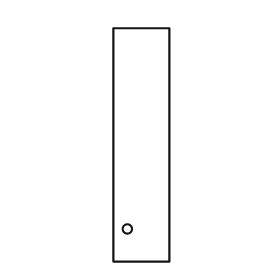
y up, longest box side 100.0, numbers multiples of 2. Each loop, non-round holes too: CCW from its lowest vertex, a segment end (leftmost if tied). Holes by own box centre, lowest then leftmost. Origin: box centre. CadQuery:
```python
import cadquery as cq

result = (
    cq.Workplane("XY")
    .moveTo(-12.0, -50.0)
    .lineTo(12.0, -50.0)
    .lineTo(12.0, 50.0)
    .lineTo(-12.0, 50.0)
    .close()
    .moveTo(-6.0, -36.0)
    .circle(2.0)
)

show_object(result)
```